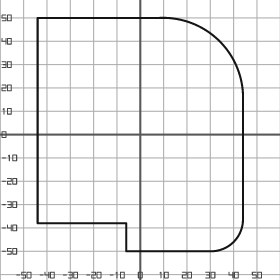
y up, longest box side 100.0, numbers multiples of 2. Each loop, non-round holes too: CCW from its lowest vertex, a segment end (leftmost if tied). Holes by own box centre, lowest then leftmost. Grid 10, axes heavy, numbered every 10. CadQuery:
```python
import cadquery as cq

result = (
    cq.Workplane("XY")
    .moveTo(-6.0, -50.0)
    .lineTo(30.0, -50.0)
    .threePointArc((40.0, -46.0), (44.0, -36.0))
    .lineTo(44.0, 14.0)
    .threePointArc((34.0, 40.0), (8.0, 50.0))
    .lineTo(-44.0, 50.0)
    .lineTo(-44.0, -38.0)
    .lineTo(-6.0, -38.0)
    .close()
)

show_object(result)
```